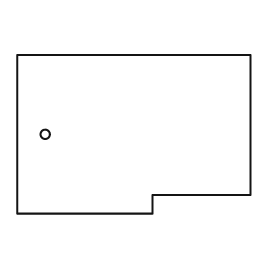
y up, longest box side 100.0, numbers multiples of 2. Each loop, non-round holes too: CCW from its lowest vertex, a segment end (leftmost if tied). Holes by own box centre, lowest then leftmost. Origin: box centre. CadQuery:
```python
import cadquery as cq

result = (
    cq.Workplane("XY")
    .moveTo(-50.0, -34.0)
    .lineTo(8.0, -34.0)
    .lineTo(8.0, -26.0)
    .lineTo(50.0, -26.0)
    .lineTo(50.0, 34.0)
    .lineTo(-50.0, 34.0)
    .close()
    .moveTo(-38.0, 0.0)
    .circle(2.0)
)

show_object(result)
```